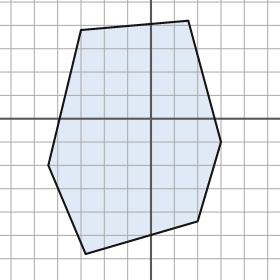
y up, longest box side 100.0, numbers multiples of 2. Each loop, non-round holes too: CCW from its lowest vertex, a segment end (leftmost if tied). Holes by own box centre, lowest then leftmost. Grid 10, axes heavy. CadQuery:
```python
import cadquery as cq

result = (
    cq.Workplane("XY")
    .moveTo(-28.0, -58.0)
    .lineTo(20.0, -44.0)
    .lineTo(30.0, -10.0)
    .lineTo(16.0, 42.0)
    .lineTo(-30.0, 38.0)
    .lineTo(-44.0, -20.0)
    .close()
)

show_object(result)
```